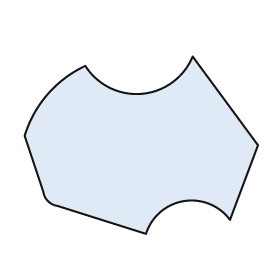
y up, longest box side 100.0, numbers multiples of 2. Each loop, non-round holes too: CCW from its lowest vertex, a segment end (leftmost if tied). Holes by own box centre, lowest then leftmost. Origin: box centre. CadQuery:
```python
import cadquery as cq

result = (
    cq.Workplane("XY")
    .moveTo(2.0, -38.0)
    .threePointArc((18.0, -24.0), (38.0, -32.0))
    .lineTo(50.0, 0.0)
    .lineTo(22.0, 38.0)
    .threePointArc((0.0, 22.0), (-24.0, 34.0))
    .threePointArc((-40.0, 22.0), (-50.0, 4.0))
    .lineTo(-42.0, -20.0)
    .threePointArc((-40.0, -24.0), (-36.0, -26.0))
    .close()
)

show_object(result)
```